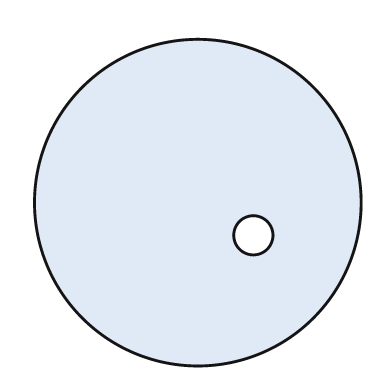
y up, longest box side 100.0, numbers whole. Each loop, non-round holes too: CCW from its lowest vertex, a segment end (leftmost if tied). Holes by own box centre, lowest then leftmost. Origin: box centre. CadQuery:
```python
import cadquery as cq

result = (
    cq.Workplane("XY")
    .moveTo(0.0, 0.0)
    .circle(50.0)
    .moveTo(17.0, -10.0)
    .circle(6.0)
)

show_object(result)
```